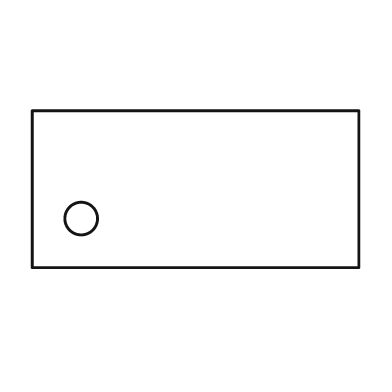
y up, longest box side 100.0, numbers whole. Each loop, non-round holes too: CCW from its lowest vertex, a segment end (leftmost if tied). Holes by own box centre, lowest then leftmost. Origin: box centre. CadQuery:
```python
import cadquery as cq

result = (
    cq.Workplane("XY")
    .moveTo(-50.0, -24.0)
    .lineTo(50.0, -24.0)
    .lineTo(50.0, 24.0)
    .lineTo(-50.0, 24.0)
    .close()
    .moveTo(-35.0, -9.0)
    .circle(5.0)
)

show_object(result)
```